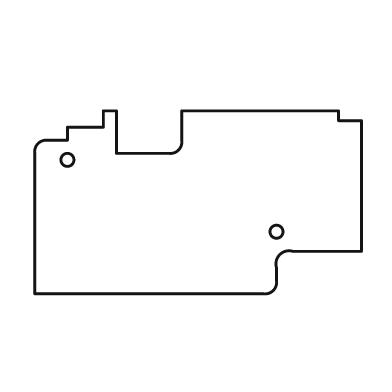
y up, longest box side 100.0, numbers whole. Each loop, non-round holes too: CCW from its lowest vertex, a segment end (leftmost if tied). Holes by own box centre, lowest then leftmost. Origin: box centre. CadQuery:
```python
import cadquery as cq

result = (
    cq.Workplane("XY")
    .moveTo(-50.0, -28.0)
    .lineTo(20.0, -28.0)
    .threePointArc((23.0, -27.0), (24.0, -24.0))
    .lineTo(24.0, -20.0)
    .threePointArc((25.0, -16.0), (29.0, -15.0))
    .lineTo(50.0, -15.0)
    .lineTo(50.0, 25.0)
    .lineTo(43.0, 25.0)
    .lineTo(43.0, 28.0)
    .lineTo(-5.0, 28.0)
    .lineTo(-5.0, 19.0)
    .threePointArc((-6.0, 16.0), (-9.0, 15.0))
    .lineTo(-25.0, 15.0)
    .lineTo(-25.0, 28.0)
    .lineTo(-29.0, 28.0)
    .lineTo(-29.0, 23.0)
    .lineTo(-40.0, 23.0)
    .lineTo(-40.0, 19.0)
    .lineTo(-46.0, 19.0)
    .threePointArc((-49.0, 18.0), (-50.0, 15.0))
    .close()
    .moveTo(24.0, -9.0)
    .circle(2.0)
    .moveTo(-40.0, 13.0)
    .circle(2.0)
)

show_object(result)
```